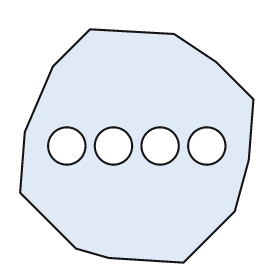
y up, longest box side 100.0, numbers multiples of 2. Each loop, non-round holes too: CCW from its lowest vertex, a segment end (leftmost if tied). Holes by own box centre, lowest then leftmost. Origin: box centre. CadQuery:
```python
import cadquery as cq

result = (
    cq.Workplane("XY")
    .moveTo(20.0, -50.0)
    .lineTo(42.0, -28.0)
    .lineTo(48.0, -6.0)
    .lineTo(50.0, 20.0)
    .lineTo(34.0, 36.0)
    .lineTo(16.0, 48.0)
    .lineTo(-20.0, 50.0)
    .lineTo(-36.0, 34.0)
    .lineTo(-48.0, 6.0)
    .lineTo(-50.0, -20.0)
    .lineTo(-26.0, -44.0)
    .lineTo(-12.0, -48.0)
    .close()
    .moveTo(-30.0, 0.0)
    .circle(8.0)
    .moveTo(-10.0, 0.0)
    .circle(8.0)
    .moveTo(10.0, 0.0)
    .circle(8.0)
    .moveTo(30.0, 0.0)
    .circle(8.0)
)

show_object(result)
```